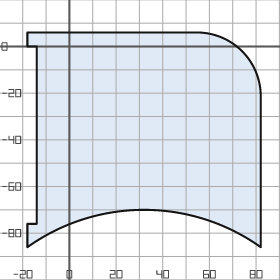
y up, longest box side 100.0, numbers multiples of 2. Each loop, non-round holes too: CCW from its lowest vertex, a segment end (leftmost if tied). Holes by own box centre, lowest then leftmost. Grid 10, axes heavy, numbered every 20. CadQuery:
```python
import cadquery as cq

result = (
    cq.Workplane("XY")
    .moveTo(-18.0, -86.0)
    .threePointArc((32.0, -70.0), (82.0, -86.0))
    .lineTo(82.0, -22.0)
    .threePointArc((74.0, -2.0), (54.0, 6.0))
    .lineTo(-18.0, 6.0)
    .lineTo(-18.0, 0.0)
    .lineTo(-14.0, 0.0)
    .lineTo(-14.0, -76.0)
    .lineTo(-18.0, -76.0)
    .close()
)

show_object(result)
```